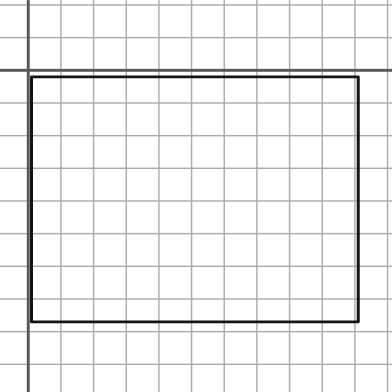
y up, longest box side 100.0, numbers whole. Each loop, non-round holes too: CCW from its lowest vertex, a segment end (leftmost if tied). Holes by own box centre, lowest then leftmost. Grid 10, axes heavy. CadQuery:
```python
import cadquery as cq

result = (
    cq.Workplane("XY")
    .moveTo(1.0, -77.0)
    .lineTo(101.0, -77.0)
    .lineTo(101.0, -2.0)
    .lineTo(1.0, -2.0)
    .close()
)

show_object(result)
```